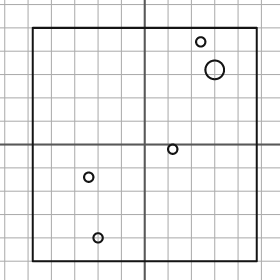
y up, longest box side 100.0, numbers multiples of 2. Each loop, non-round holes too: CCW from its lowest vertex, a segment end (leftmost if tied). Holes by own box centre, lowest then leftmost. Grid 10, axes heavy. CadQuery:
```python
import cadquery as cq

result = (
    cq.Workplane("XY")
    .moveTo(-48.0, -50.0)
    .lineTo(48.0, -50.0)
    .lineTo(48.0, 50.0)
    .lineTo(-48.0, 50.0)
    .close()
    .moveTo(-20.0, -40.0)
    .circle(2.0)
    .moveTo(-24.0, -14.0)
    .circle(2.0)
    .moveTo(12.0, -2.0)
    .circle(2.0)
    .moveTo(30.0, 32.0)
    .circle(4.0)
    .moveTo(24.0, 44.0)
    .circle(2.0)
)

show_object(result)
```